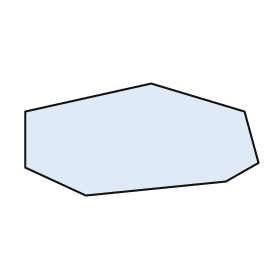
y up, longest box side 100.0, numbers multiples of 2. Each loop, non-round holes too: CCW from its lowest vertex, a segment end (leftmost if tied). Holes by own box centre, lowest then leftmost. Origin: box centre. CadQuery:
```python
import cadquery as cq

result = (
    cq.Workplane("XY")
    .moveTo(-24.0, -24.0)
    .lineTo(36.0, -18.0)
    .lineTo(50.0, -10.0)
    .lineTo(44.0, 12.0)
    .lineTo(4.0, 24.0)
    .lineTo(-50.0, 12.0)
    .lineTo(-50.0, -12.0)
    .close()
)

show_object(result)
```